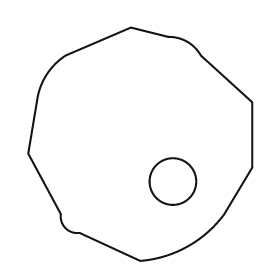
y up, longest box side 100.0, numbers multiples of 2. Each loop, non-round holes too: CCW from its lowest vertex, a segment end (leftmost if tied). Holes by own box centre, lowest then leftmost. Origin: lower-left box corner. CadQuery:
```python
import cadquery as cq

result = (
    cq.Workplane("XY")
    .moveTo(48.0, 0.0)
    .threePointArc((68.0, 6.0), (84.0, 20.0))
    .lineTo(96.0, 40.0)
    .lineTo(96.0, 68.0)
    .lineTo(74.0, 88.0)
    .threePointArc((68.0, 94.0), (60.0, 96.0))
    .lineTo(44.0, 100.0)
    .lineTo(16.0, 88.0)
    .threePointArc((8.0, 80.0), (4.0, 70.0))
    .lineTo(0.0, 46.0)
    .lineTo(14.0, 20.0)
    .threePointArc((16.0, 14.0), (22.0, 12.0))
    .close()
    .moveTo(62.0, 34.0)
    .circle(10.0)
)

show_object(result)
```